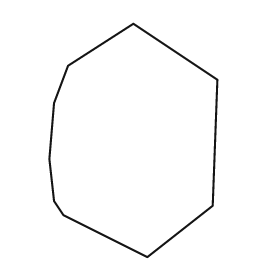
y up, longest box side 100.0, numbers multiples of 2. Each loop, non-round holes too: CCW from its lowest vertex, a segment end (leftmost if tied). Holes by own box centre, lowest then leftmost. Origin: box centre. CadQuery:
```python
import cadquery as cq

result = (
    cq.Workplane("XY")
    .moveTo(6.0, -50.0)
    .lineTo(34.0, -28.0)
    .lineTo(36.0, 26.0)
    .lineTo(0.0, 50.0)
    .lineTo(-28.0, 32.0)
    .lineTo(-34.0, 16.0)
    .lineTo(-36.0, -8.0)
    .lineTo(-34.0, -26.0)
    .lineTo(-30.0, -32.0)
    .close()
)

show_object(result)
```